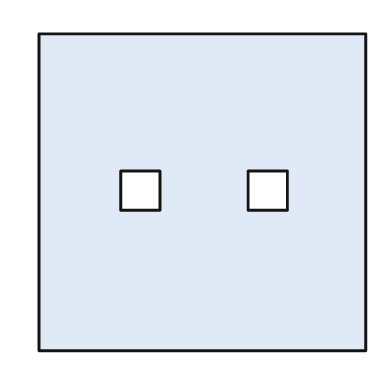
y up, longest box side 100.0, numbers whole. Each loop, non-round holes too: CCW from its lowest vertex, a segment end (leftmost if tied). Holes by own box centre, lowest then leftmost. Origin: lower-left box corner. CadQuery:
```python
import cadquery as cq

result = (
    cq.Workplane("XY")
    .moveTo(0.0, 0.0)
    .lineTo(100.0, 0.0)
    .lineTo(100.0, 97.0)
    .lineTo(0.0, 97.0)
    .close()
    .moveTo(25.0, 43.0)
    .lineTo(37.0, 43.0)
    .lineTo(37.0, 55.0)
    .lineTo(25.0, 55.0)
    .close()
    .moveTo(64.0, 43.0)
    .lineTo(76.0, 43.0)
    .lineTo(76.0, 55.0)
    .lineTo(64.0, 55.0)
    .close()
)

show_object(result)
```